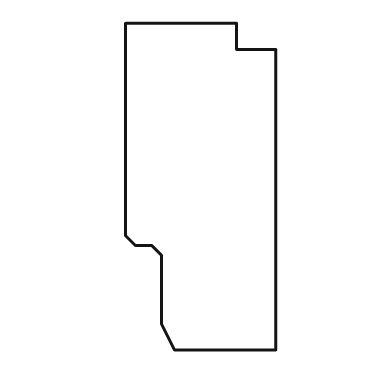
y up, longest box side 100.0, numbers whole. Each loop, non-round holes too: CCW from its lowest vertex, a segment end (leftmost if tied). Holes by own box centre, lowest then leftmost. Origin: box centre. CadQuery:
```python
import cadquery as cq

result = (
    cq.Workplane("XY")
    .moveTo(-8.0, -50.0)
    .lineTo(23.0, -50.0)
    .lineTo(23.0, 42.0)
    .lineTo(11.0, 42.0)
    .lineTo(11.0, 50.0)
    .lineTo(-23.0, 50.0)
    .lineTo(-23.0, -15.0)
    .lineTo(-20.0, -18.0)
    .lineTo(-15.0, -18.0)
    .lineTo(-12.0, -21.0)
    .lineTo(-12.0, -42.0)
    .close()
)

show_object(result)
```